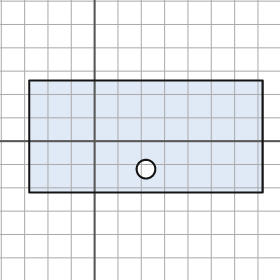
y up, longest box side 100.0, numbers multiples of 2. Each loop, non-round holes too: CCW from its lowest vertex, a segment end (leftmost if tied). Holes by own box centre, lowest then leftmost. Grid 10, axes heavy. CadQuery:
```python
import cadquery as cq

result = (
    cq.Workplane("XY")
    .moveTo(-28.0, -22.0)
    .lineTo(72.0, -22.0)
    .lineTo(72.0, 26.0)
    .lineTo(-28.0, 26.0)
    .close()
    .moveTo(22.0, -12.0)
    .circle(4.0)
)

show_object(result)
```